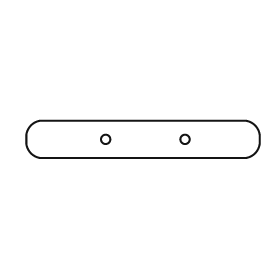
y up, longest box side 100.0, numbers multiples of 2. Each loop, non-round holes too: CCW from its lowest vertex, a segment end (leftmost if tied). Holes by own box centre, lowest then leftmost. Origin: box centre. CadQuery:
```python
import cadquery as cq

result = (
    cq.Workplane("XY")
    .moveTo(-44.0, -8.0)
    .lineTo(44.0, -8.0)
    .threePointArc((48.0, -6.0), (50.0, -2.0))
    .lineTo(50.0, 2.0)
    .threePointArc((48.0, 6.0), (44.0, 8.0))
    .lineTo(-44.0, 8.0)
    .threePointArc((-48.0, 6.0), (-50.0, 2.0))
    .lineTo(-50.0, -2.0)
    .threePointArc((-48.0, -6.0), (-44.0, -8.0))
    .close()
    .moveTo(-16.0, 0.0)
    .circle(2.0)
    .moveTo(18.0, 0.0)
    .circle(2.0)
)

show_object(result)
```